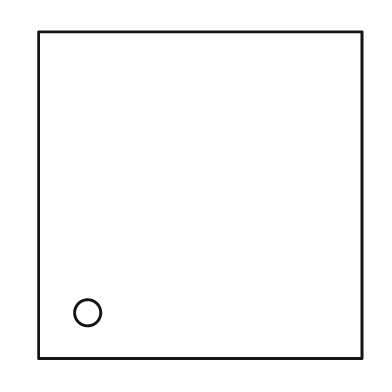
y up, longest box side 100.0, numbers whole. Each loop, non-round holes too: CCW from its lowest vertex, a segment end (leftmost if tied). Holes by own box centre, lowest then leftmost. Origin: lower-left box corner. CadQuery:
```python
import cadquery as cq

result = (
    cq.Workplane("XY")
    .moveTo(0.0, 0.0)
    .lineTo(99.0, 0.0)
    .lineTo(99.0, 100.0)
    .lineTo(0.0, 100.0)
    .close()
    .moveTo(15.0, 14.0)
    .circle(4.0)
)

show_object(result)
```